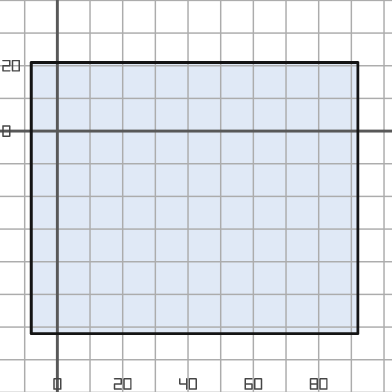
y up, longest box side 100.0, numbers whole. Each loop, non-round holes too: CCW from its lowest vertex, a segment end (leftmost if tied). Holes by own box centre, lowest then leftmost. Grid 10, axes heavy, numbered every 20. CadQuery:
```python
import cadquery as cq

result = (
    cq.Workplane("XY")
    .moveTo(-8.0, -62.0)
    .lineTo(92.0, -62.0)
    .lineTo(92.0, 21.0)
    .lineTo(-8.0, 21.0)
    .close()
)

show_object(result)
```